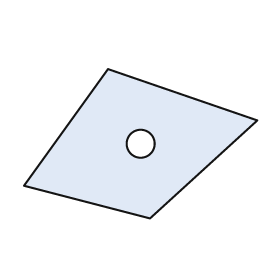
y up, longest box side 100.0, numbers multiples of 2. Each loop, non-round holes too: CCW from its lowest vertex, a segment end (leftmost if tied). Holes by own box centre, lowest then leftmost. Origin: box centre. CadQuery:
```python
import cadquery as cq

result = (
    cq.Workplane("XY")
    .moveTo(4.0, -32.0)
    .lineTo(50.0, 10.0)
    .lineTo(-14.0, 32.0)
    .lineTo(-50.0, -18.0)
    .close()
    .moveTo(0.0, 0.0)
    .circle(6.0)
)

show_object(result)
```